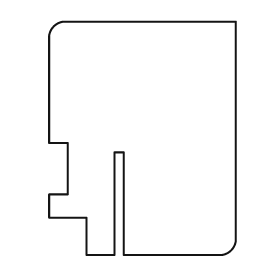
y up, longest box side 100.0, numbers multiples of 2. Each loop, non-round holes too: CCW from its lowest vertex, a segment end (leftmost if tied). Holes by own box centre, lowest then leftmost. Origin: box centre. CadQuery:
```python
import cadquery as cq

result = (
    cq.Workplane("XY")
    .moveTo(-24.0, -50.0)
    .lineTo(-12.0, -50.0)
    .lineTo(-12.0, -6.0)
    .lineTo(-8.0, -6.0)
    .lineTo(-8.0, -50.0)
    .lineTo(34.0, -50.0)
    .threePointArc((38.0, -48.0), (40.0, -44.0))
    .lineTo(40.0, 50.0)
    .lineTo(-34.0, 50.0)
    .threePointArc((-38.0, 48.0), (-40.0, 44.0))
    .lineTo(-40.0, -2.0)
    .lineTo(-32.0, -2.0)
    .lineTo(-32.0, -24.0)
    .lineTo(-40.0, -24.0)
    .lineTo(-40.0, -34.0)
    .lineTo(-24.0, -34.0)
    .close()
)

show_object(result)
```